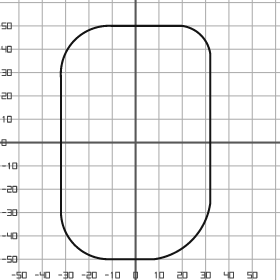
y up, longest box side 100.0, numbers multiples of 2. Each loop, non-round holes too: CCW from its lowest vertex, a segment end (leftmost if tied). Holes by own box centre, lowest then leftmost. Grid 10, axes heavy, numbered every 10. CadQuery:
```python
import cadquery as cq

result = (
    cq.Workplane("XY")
    .moveTo(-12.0, -50.0)
    .lineTo(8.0, -50.0)
    .threePointArc((24.0, -42.0), (32.0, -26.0))
    .lineTo(32.0, 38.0)
    .threePointArc((28.0, 46.0), (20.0, 50.0))
    .lineTo(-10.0, 50.0)
    .threePointArc((-26.0, 44.0), (-32.0, 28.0))
    .lineTo(-32.0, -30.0)
    .threePointArc((-26.0, -44.0), (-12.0, -50.0))
    .close()
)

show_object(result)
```